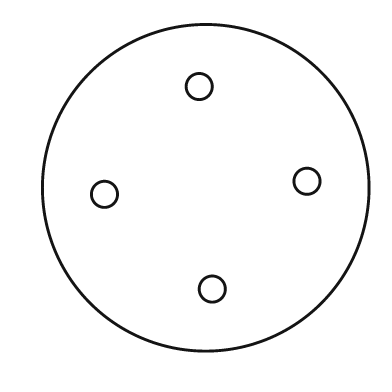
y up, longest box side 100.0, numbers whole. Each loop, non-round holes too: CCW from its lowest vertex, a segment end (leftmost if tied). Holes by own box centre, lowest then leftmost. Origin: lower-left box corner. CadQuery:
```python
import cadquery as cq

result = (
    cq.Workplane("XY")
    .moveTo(50.0, 50.0)
    .circle(50.0)
    .moveTo(52.0, 19.0)
    .circle(4.0)
    .moveTo(19.0, 48.0)
    .circle(4.0)
    .moveTo(81.0, 52.0)
    .circle(4.0)
    .moveTo(48.0, 81.0)
    .circle(4.0)
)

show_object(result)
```